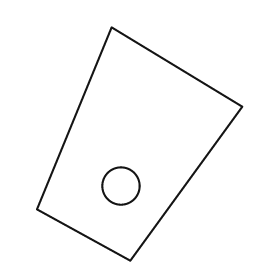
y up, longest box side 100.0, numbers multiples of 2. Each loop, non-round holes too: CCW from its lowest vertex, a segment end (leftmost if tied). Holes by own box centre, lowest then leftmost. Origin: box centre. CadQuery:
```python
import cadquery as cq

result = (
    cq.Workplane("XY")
    .moveTo(-4.0, -50.0)
    .lineTo(44.0, 16.0)
    .lineTo(-12.0, 50.0)
    .lineTo(-44.0, -28.0)
    .close()
    .moveTo(-8.0, -18.0)
    .circle(8.0)
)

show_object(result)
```